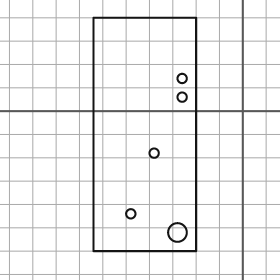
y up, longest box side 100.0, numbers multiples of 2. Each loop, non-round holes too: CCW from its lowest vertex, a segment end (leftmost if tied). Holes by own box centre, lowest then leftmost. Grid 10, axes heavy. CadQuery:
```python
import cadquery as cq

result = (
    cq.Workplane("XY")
    .moveTo(-64.0, -60.0)
    .lineTo(-20.0, -60.0)
    .lineTo(-20.0, 40.0)
    .lineTo(-64.0, 40.0)
    .close()
    .moveTo(-28.0, -52.0)
    .circle(4.0)
    .moveTo(-48.0, -44.0)
    .circle(2.0)
    .moveTo(-38.0, -18.0)
    .circle(2.0)
    .moveTo(-26.0, 6.0)
    .circle(2.0)
    .moveTo(-26.0, 14.0)
    .circle(2.0)
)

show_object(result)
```